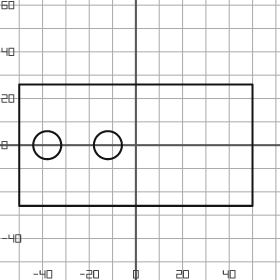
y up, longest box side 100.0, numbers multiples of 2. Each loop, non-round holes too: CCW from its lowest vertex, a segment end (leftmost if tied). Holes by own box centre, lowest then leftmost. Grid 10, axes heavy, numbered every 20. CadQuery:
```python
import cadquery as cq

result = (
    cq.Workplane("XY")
    .moveTo(-50.0, -26.0)
    .lineTo(50.0, -26.0)
    .lineTo(50.0, 26.0)
    .lineTo(-50.0, 26.0)
    .close()
    .moveTo(-38.0, 0.0)
    .circle(6.0)
    .moveTo(-12.0, 0.0)
    .circle(6.0)
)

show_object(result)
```